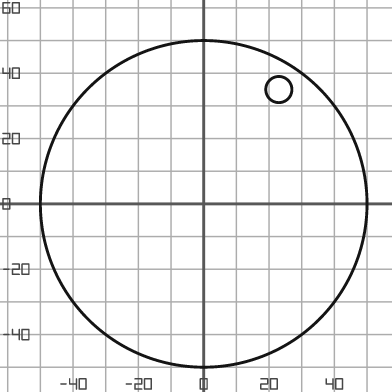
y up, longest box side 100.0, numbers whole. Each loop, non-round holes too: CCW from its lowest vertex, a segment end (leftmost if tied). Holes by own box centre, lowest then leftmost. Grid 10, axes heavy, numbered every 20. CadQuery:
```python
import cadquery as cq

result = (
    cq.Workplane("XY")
    .moveTo(0.0, 0.0)
    .circle(50.0)
    .moveTo(23.0, 35.0)
    .circle(4.0)
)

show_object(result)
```